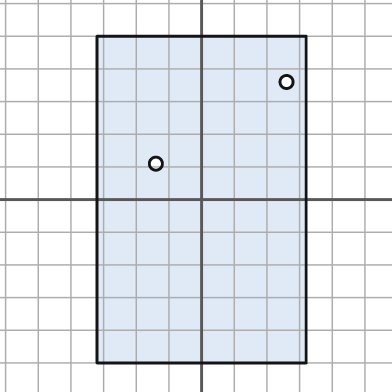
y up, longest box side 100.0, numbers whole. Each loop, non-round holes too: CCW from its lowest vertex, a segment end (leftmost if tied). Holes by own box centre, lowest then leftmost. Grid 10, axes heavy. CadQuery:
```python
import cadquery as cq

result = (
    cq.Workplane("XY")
    .moveTo(-32.0, -50.0)
    .lineTo(32.0, -50.0)
    .lineTo(32.0, 50.0)
    .lineTo(-32.0, 50.0)
    .close()
    .moveTo(-14.0, 11.0)
    .circle(2.0)
    .moveTo(26.0, 36.0)
    .circle(2.0)
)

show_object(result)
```